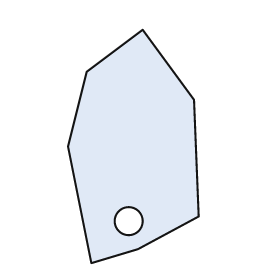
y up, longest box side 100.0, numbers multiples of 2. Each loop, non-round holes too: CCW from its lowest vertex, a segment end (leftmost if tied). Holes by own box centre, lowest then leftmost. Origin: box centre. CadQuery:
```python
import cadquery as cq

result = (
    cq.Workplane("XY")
    .moveTo(-18.0, -50.0)
    .lineTo(2.0, -44.0)
    .lineTo(28.0, -30.0)
    .lineTo(26.0, 20.0)
    .lineTo(4.0, 50.0)
    .lineTo(-20.0, 32.0)
    .lineTo(-28.0, 0.0)
    .close()
    .moveTo(-2.0, -32.0)
    .circle(6.0)
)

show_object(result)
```